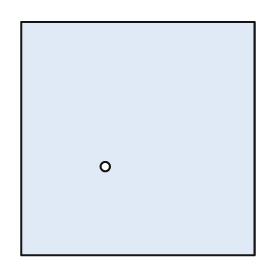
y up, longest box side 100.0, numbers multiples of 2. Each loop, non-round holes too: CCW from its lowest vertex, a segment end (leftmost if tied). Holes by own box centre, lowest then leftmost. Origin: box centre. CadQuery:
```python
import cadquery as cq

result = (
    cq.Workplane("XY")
    .moveTo(-50.0, -50.0)
    .lineTo(50.0, -50.0)
    .lineTo(50.0, 50.0)
    .lineTo(-50.0, 50.0)
    .close()
    .moveTo(-14.0, -12.0)
    .circle(2.0)
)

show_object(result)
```